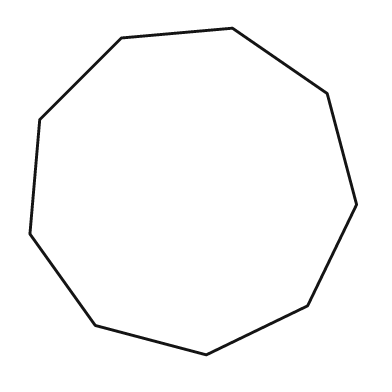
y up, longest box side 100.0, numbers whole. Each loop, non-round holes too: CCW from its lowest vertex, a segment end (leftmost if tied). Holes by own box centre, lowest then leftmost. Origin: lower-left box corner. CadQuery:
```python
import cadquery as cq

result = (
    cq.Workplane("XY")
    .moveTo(54.0, 0.0)
    .lineTo(85.0, 15.0)
    .lineTo(100.0, 46.0)
    .lineTo(91.0, 80.0)
    .lineTo(62.0, 100.0)
    .lineTo(28.0, 97.0)
    .lineTo(3.0, 72.0)
    .lineTo(0.0, 37.0)
    .lineTo(20.0, 9.0)
    .close()
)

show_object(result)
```